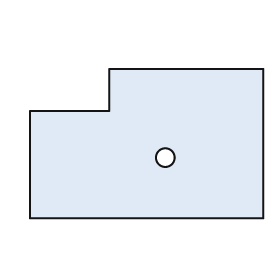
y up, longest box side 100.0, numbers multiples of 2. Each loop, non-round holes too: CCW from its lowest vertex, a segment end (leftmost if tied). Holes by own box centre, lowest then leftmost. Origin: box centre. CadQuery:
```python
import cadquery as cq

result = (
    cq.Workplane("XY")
    .moveTo(-50.0, -32.0)
    .lineTo(50.0, -32.0)
    .lineTo(50.0, 32.0)
    .lineTo(-16.0, 32.0)
    .lineTo(-16.0, 14.0)
    .lineTo(-50.0, 14.0)
    .close()
    .moveTo(8.0, -6.0)
    .circle(4.0)
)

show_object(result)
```